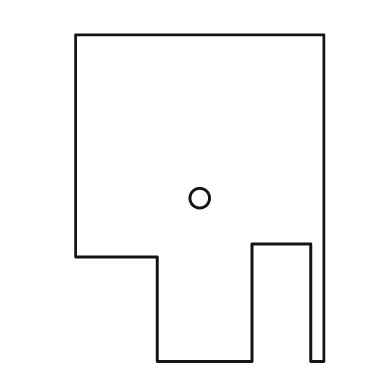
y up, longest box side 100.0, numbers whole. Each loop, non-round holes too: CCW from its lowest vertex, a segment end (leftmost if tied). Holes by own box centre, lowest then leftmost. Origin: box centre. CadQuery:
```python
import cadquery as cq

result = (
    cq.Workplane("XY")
    .moveTo(-13.0, -50.0)
    .lineTo(16.0, -50.0)
    .lineTo(16.0, -14.0)
    .lineTo(34.0, -14.0)
    .lineTo(34.0, -50.0)
    .lineTo(38.0, -50.0)
    .lineTo(38.0, 50.0)
    .lineTo(-38.0, 50.0)
    .lineTo(-38.0, -18.0)
    .lineTo(-13.0, -18.0)
    .close()
    .moveTo(0.0, 0.0)
    .circle(3.0)
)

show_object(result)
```